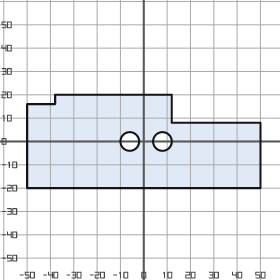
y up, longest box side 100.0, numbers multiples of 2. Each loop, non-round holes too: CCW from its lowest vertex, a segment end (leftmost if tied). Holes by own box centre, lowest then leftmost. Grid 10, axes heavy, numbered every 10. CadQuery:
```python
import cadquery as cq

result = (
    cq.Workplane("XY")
    .moveTo(-50.0, -20.0)
    .lineTo(50.0, -20.0)
    .lineTo(50.0, 8.0)
    .lineTo(12.0, 8.0)
    .lineTo(12.0, 20.0)
    .lineTo(-38.0, 20.0)
    .lineTo(-38.0, 16.0)
    .lineTo(-50.0, 16.0)
    .close()
    .moveTo(-6.0, 0.0)
    .circle(4.0)
    .moveTo(8.0, 0.0)
    .circle(4.0)
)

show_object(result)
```